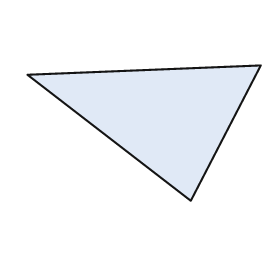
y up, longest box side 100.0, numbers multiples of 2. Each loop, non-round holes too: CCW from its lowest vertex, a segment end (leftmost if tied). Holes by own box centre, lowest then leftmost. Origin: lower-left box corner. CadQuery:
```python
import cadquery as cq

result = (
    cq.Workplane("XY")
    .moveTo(70.0, 0.0)
    .lineTo(100.0, 58.0)
    .lineTo(0.0, 54.0)
    .close()
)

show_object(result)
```